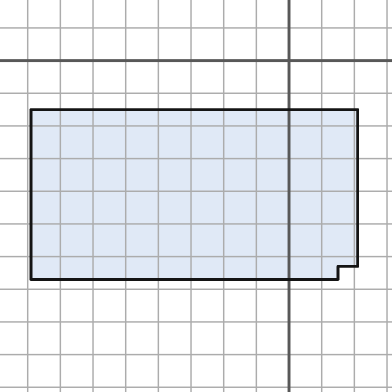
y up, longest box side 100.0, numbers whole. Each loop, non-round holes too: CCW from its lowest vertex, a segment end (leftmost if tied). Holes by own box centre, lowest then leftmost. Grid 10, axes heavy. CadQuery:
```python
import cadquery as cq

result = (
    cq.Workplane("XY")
    .moveTo(-79.0, -67.0)
    .lineTo(15.0, -67.0)
    .lineTo(15.0, -63.0)
    .lineTo(21.0, -63.0)
    .lineTo(21.0, -15.0)
    .lineTo(-79.0, -15.0)
    .close()
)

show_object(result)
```